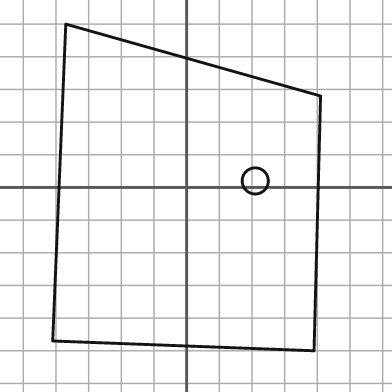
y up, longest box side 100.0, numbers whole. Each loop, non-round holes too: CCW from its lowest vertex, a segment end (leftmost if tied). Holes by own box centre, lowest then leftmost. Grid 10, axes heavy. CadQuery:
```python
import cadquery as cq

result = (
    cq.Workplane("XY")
    .moveTo(39.0, -50.0)
    .lineTo(41.0, 28.0)
    .lineTo(-37.0, 50.0)
    .lineTo(-41.0, -47.0)
    .close()
    .moveTo(21.0, 2.0)
    .circle(4.0)
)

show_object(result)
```